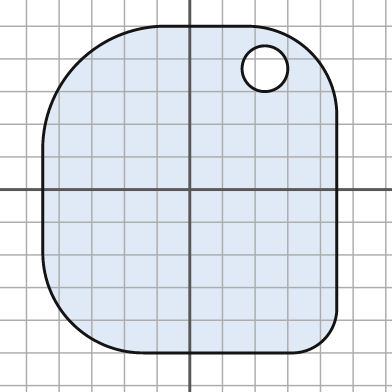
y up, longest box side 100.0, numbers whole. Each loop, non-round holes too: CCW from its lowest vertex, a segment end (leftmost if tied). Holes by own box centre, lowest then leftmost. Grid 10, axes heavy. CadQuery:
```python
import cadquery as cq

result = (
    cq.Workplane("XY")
    .moveTo(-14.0, -50.0)
    .lineTo(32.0, -50.0)
    .threePointArc((41.0, -46.0), (45.0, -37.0))
    .lineTo(45.0, 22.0)
    .threePointArc((37.0, 42.0), (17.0, 50.0))
    .lineTo(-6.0, 50.0)
    .threePointArc((-34.0, 39.0), (-45.0, 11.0))
    .lineTo(-45.0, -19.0)
    .threePointArc((-36.0, -41.0), (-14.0, -50.0))
    .close()
    .moveTo(23.0, 37.0)
    .circle(7.0)
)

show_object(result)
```